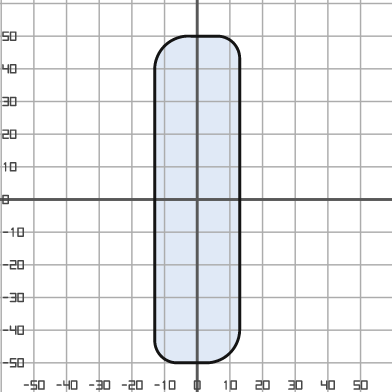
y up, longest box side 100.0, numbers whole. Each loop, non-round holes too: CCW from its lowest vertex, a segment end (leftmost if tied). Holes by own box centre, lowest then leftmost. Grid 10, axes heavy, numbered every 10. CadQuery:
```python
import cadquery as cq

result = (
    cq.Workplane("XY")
    .moveTo(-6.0, -50.0)
    .lineTo(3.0, -50.0)
    .threePointArc((10.0, -47.0), (13.0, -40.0))
    .lineTo(13.0, 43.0)
    .threePointArc((11.0, 48.0), (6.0, 50.0))
    .lineTo(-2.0, 50.0)
    .threePointArc((-10.0, 47.0), (-13.0, 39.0))
    .lineTo(-13.0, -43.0)
    .threePointArc((-11.0, -48.0), (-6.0, -50.0))
    .close()
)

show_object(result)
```